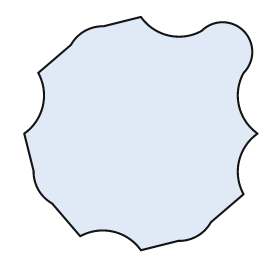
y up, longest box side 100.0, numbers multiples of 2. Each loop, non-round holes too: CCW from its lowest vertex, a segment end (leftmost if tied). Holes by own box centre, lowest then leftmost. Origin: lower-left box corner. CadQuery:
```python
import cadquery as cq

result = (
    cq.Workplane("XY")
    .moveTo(50.0, 0.0)
    .lineTo(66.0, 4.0)
    .threePointArc((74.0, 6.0), (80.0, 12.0))
    .lineTo(94.0, 24.0)
    .threePointArc((92.0, 38.0), (100.0, 50.0))
    .threePointArc((92.0, 62.0), (94.0, 76.0))
    .threePointArc((94.0, 94.0), (76.0, 94.0))
    .threePointArc((62.0, 92.0), (50.0, 100.0))
    .lineTo(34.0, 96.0)
    .threePointArc((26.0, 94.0), (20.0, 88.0))
    .lineTo(6.0, 76.0)
    .threePointArc((8.0, 62.0), (0.0, 50.0))
    .lineTo(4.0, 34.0)
    .threePointArc((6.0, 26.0), (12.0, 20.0))
    .lineTo(24.0, 6.0)
    .threePointArc((38.0, 8.0), (50.0, 0.0))
    .close()
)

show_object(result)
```